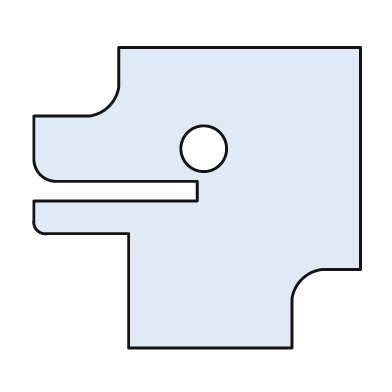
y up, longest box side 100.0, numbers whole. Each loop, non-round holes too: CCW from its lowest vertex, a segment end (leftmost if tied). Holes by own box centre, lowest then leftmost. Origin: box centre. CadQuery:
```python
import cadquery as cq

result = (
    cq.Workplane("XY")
    .moveTo(-21.0, -46.0)
    .lineTo(29.0, -46.0)
    .lineTo(29.0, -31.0)
    .threePointArc((32.0, -25.0), (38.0, -22.0))
    .lineTo(50.0, -22.0)
    .lineTo(50.0, 46.0)
    .lineTo(-24.0, 46.0)
    .lineTo(-24.0, 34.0)
    .threePointArc((-27.0, 28.0), (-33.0, 25.0))
    .lineTo(-50.0, 25.0)
    .lineTo(-50.0, 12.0)
    .threePointArc((-48.0, 7.0), (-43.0, 5.0))
    .lineTo(0.0, 5.0)
    .lineTo(0.0, -1.0)
    .lineTo(-50.0, -1.0)
    .lineTo(-50.0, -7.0)
    .threePointArc((-49.0, -10.0), (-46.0, -11.0))
    .lineTo(-21.0, -11.0)
    .close()
    .moveTo(2.0, 15.0)
    .circle(7.0)
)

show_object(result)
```